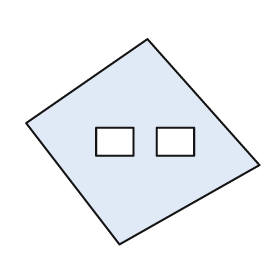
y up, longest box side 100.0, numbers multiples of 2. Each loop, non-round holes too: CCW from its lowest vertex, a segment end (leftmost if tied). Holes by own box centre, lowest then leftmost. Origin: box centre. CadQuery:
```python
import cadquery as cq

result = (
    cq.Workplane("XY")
    .moveTo(-10.0, -44.0)
    .lineTo(50.0, -10.0)
    .lineTo(2.0, 44.0)
    .lineTo(-50.0, 8.0)
    .close()
    .moveTo(-20.0, -6.0)
    .lineTo(-4.0, -6.0)
    .lineTo(-4.0, 6.0)
    .lineTo(-20.0, 6.0)
    .close()
    .moveTo(6.0, -6.0)
    .lineTo(22.0, -6.0)
    .lineTo(22.0, 6.0)
    .lineTo(6.0, 6.0)
    .close()
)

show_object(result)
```